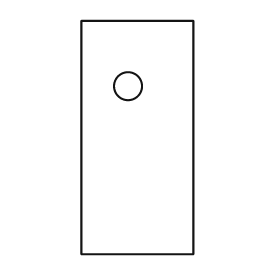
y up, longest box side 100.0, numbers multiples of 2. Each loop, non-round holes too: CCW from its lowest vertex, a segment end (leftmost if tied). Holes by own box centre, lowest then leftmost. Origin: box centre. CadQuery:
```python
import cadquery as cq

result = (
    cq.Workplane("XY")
    .moveTo(-24.0, -50.0)
    .lineTo(24.0, -50.0)
    .lineTo(24.0, 50.0)
    .lineTo(-24.0, 50.0)
    .close()
    .moveTo(-4.0, 22.0)
    .circle(6.0)
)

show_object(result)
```